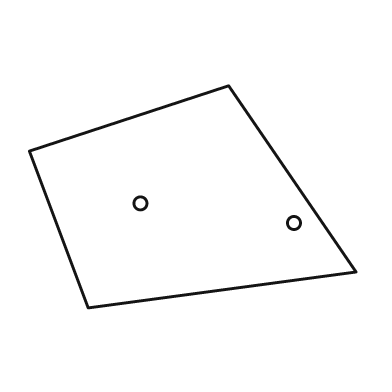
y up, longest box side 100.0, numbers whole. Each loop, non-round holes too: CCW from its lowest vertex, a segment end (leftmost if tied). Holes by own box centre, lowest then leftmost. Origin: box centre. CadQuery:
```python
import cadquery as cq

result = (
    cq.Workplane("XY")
    .moveTo(-32.0, -34.0)
    .lineTo(50.0, -23.0)
    .lineTo(11.0, 34.0)
    .lineTo(-50.0, 14.0)
    .close()
    .moveTo(31.0, -8.0)
    .circle(2.0)
    .moveTo(-16.0, -2.0)
    .circle(2.0)
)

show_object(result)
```